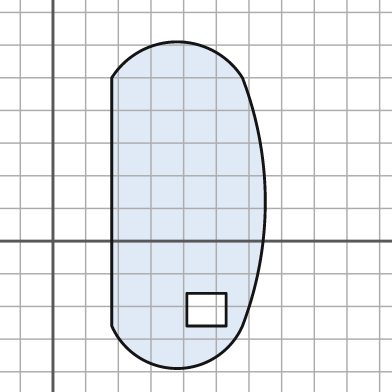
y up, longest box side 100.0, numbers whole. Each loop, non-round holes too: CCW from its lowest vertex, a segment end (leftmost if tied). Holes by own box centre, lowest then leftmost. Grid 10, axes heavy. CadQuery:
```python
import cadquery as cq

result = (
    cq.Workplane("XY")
    .moveTo(18.0, -26.0)
    .threePointArc((38.0, -39.0), (58.0, -26.0))
    .threePointArc((65.0, 12.0), (58.0, 50.0))
    .threePointArc((38.0, 61.0), (18.0, 50.0))
    .close()
    .moveTo(41.0, -26.0)
    .lineTo(53.0, -26.0)
    .lineTo(53.0, -16.0)
    .lineTo(41.0, -16.0)
    .close()
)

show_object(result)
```